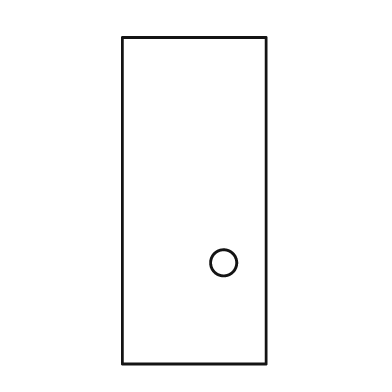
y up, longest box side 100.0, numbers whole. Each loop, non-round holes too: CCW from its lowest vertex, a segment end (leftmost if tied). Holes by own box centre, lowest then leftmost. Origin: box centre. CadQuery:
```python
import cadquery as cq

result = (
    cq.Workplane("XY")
    .moveTo(-22.0, -50.0)
    .lineTo(22.0, -50.0)
    .lineTo(22.0, 50.0)
    .lineTo(-22.0, 50.0)
    .close()
    .moveTo(9.0, -19.0)
    .circle(4.0)
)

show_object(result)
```